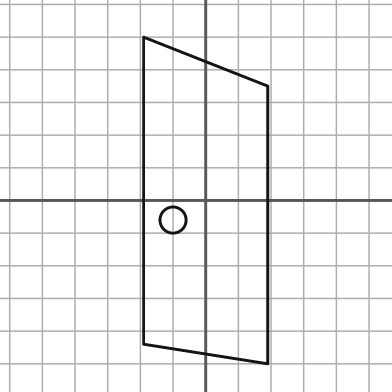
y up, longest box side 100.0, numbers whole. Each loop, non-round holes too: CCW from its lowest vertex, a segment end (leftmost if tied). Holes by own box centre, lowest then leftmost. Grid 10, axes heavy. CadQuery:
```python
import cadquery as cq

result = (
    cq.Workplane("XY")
    .moveTo(19.0, -50.0)
    .lineTo(19.0, 35.0)
    .lineTo(-19.0, 50.0)
    .lineTo(-19.0, -44.0)
    .close()
    .moveTo(-10.0, -6.0)
    .circle(4.0)
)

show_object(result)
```